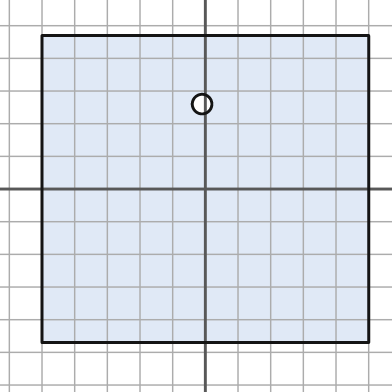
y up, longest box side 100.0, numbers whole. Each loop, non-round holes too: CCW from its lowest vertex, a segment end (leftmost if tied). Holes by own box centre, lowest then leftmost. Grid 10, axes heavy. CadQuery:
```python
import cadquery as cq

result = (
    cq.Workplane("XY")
    .moveTo(-50.0, -47.0)
    .lineTo(50.0, -47.0)
    .lineTo(50.0, 47.0)
    .lineTo(-50.0, 47.0)
    .close()
    .moveTo(-1.0, 26.0)
    .circle(3.0)
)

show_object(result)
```